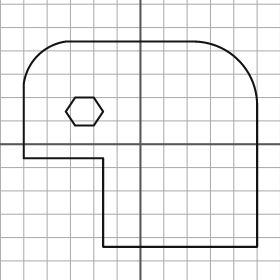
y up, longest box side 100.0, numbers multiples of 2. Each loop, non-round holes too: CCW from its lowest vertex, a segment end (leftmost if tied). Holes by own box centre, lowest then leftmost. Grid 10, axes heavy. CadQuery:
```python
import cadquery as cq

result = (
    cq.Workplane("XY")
    .moveTo(-16.0, -44.0)
    .lineTo(50.0, -44.0)
    .lineTo(50.0, 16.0)
    .threePointArc((42.0, 36.0), (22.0, 44.0))
    .lineTo(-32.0, 44.0)
    .threePointArc((-44.0, 38.0), (-50.0, 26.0))
    .lineTo(-50.0, -6.0)
    .lineTo(-16.0, -6.0)
    .close()
    .moveTo(-28.0, 8.0)
    .lineTo(-20.0, 8.0)
    .lineTo(-16.0, 14.0)
    .lineTo(-20.0, 20.0)
    .lineTo(-28.0, 20.0)
    .lineTo(-32.0, 14.0)
    .close()
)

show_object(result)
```